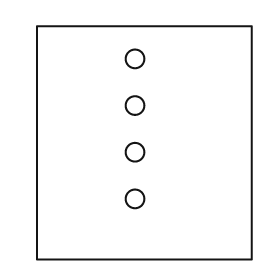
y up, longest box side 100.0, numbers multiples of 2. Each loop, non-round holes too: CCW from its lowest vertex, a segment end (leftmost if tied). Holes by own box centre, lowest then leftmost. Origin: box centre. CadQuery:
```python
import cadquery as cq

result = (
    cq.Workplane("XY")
    .moveTo(-46.0, -50.0)
    .lineTo(46.0, -50.0)
    .lineTo(46.0, 50.0)
    .lineTo(-46.0, 50.0)
    .close()
    .moveTo(-4.0, -24.0)
    .circle(4.0)
    .moveTo(-4.0, -4.0)
    .circle(4.0)
    .moveTo(-4.0, 16.0)
    .circle(4.0)
    .moveTo(-4.0, 36.0)
    .circle(4.0)
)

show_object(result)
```